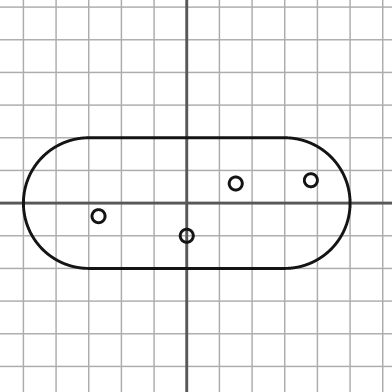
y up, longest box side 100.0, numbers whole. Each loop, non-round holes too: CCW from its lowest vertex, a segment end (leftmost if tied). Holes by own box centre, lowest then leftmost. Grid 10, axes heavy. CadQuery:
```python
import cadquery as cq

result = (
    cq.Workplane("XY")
    .moveTo(-30.0, -20.0)
    .lineTo(30.0, -20.0)
    .threePointArc((50.0, 0.0), (30.0, 20.0))
    .lineTo(-30.0, 20.0)
    .threePointArc((-50.0, 0.0), (-30.0, -20.0))
    .close()
    .moveTo(0.0, -10.0)
    .circle(2.0)
    .moveTo(-27.0, -4.0)
    .circle(2.0)
    .moveTo(15.0, 6.0)
    .circle(2.0)
    .moveTo(38.0, 7.0)
    .circle(2.0)
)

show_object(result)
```